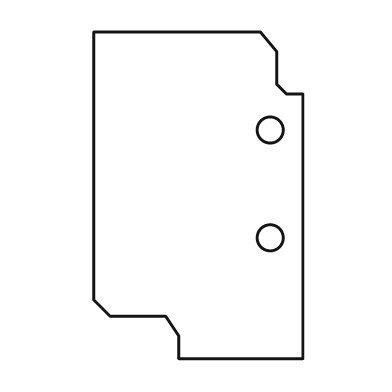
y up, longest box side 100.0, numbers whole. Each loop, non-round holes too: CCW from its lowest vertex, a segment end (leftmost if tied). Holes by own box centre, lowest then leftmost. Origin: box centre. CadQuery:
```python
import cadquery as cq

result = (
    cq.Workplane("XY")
    .moveTo(-6.0, -50.0)
    .lineTo(32.0, -50.0)
    .lineTo(32.0, 31.0)
    .lineTo(27.0, 31.0)
    .lineTo(24.0, 34.0)
    .lineTo(24.0, 44.0)
    .lineTo(19.0, 50.0)
    .lineTo(-32.0, 50.0)
    .lineTo(-32.0, -32.0)
    .lineTo(-27.0, -37.0)
    .lineTo(-10.0, -37.0)
    .lineTo(-6.0, -43.0)
    .close()
    .moveTo(22.0, -13.0)
    .circle(4.0)
    .moveTo(22.0, 20.0)
    .circle(4.0)
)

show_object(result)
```